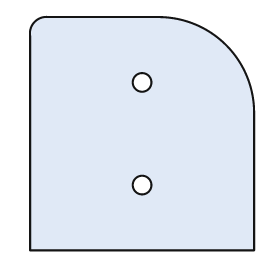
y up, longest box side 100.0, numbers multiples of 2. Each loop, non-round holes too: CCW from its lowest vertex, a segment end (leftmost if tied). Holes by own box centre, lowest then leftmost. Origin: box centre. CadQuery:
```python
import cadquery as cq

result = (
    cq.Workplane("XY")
    .moveTo(-48.0, -50.0)
    .lineTo(48.0, -50.0)
    .lineTo(48.0, 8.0)
    .threePointArc((36.0, 38.0), (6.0, 50.0))
    .lineTo(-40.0, 50.0)
    .threePointArc((-46.0, 48.0), (-48.0, 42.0))
    .close()
    .moveTo(0.0, -22.0)
    .circle(4.0)
    .moveTo(0.0, 22.0)
    .circle(4.0)
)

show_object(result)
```